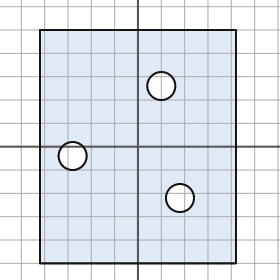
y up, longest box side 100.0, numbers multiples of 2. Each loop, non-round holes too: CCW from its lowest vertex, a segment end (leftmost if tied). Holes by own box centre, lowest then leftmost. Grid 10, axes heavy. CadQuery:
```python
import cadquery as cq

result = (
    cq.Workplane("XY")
    .moveTo(-42.0, -50.0)
    .lineTo(42.0, -50.0)
    .lineTo(42.0, 50.0)
    .lineTo(-42.0, 50.0)
    .close()
    .moveTo(18.0, -22.0)
    .circle(6.0)
    .moveTo(-28.0, -4.0)
    .circle(6.0)
    .moveTo(10.0, 26.0)
    .circle(6.0)
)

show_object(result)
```